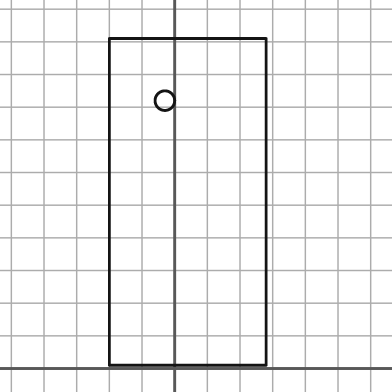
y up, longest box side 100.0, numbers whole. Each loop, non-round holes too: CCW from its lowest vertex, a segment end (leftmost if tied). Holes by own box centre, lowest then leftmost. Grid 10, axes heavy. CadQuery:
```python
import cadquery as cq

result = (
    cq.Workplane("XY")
    .moveTo(-20.0, 1.0)
    .lineTo(28.0, 1.0)
    .lineTo(28.0, 101.0)
    .lineTo(-20.0, 101.0)
    .close()
    .moveTo(-3.0, 82.0)
    .circle(3.0)
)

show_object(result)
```